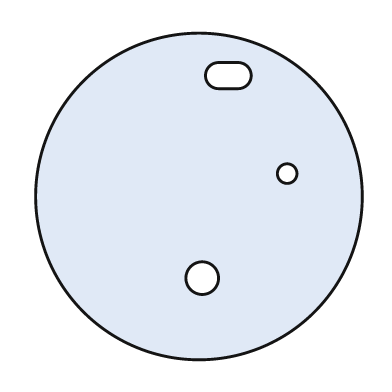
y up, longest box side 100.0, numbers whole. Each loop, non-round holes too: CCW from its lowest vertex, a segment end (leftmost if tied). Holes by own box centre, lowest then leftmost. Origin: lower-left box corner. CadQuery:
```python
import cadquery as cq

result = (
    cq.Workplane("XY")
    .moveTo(50.0, 50.0)
    .circle(50.0)
    .moveTo(51.0, 25.0)
    .circle(5.0)
    .moveTo(77.0, 57.0)
    .circle(3.0)
    .moveTo(56.0, 83.0)
    .lineTo(62.0, 83.0)
    .threePointArc((66.0, 87.0), (62.0, 91.0))
    .lineTo(56.0, 91.0)
    .threePointArc((52.0, 87.0), (56.0, 83.0))
    .close()
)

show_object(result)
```